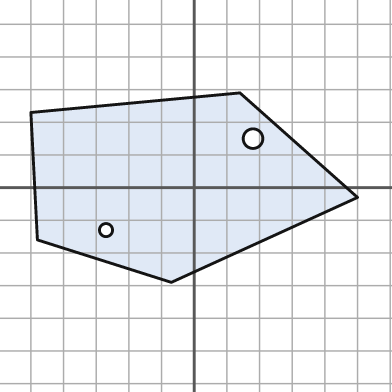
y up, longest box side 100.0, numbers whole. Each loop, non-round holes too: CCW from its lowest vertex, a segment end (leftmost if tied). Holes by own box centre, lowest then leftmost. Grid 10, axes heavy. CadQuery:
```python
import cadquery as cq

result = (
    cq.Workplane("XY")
    .moveTo(-7.0, -29.0)
    .lineTo(50.0, -3.0)
    .lineTo(14.0, 29.0)
    .lineTo(-50.0, 23.0)
    .lineTo(-48.0, -16.0)
    .close()
    .moveTo(-27.0, -13.0)
    .circle(2.0)
    .moveTo(18.0, 15.0)
    .circle(3.0)
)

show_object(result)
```